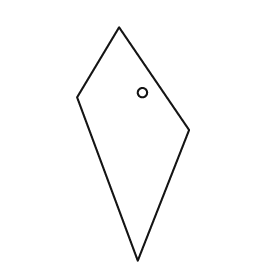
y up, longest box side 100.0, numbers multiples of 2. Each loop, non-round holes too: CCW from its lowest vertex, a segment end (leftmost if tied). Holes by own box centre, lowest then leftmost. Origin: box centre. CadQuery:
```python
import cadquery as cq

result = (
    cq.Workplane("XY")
    .moveTo(2.0, -50.0)
    .lineTo(24.0, 6.0)
    .lineTo(-6.0, 50.0)
    .lineTo(-24.0, 20.0)
    .close()
    .moveTo(4.0, 22.0)
    .circle(2.0)
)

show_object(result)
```